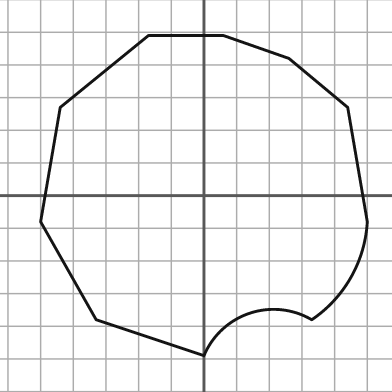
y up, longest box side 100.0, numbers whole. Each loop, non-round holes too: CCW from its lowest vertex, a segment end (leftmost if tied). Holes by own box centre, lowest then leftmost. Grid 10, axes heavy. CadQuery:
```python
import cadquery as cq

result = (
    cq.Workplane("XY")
    .moveTo(0.0, -49.0)
    .threePointArc((14.0, -36.0), (33.0, -38.0))
    .threePointArc((45.0, -25.0), (50.0, -8.0))
    .lineTo(44.0, 27.0)
    .lineTo(26.0, 42.0)
    .lineTo(6.0, 49.0)
    .lineTo(-17.0, 49.0)
    .lineTo(-44.0, 27.0)
    .lineTo(-50.0, -8.0)
    .lineTo(-33.0, -38.0)
    .close()
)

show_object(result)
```